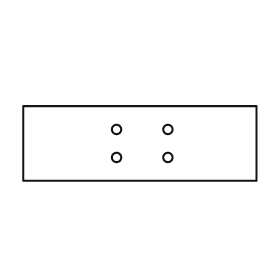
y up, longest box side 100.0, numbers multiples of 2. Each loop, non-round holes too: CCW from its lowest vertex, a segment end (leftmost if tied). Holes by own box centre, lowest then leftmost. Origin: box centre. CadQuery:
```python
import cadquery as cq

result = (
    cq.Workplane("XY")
    .moveTo(-50.0, -16.0)
    .lineTo(50.0, -16.0)
    .lineTo(50.0, 16.0)
    .lineTo(-50.0, 16.0)
    .close()
    .moveTo(-10.0, -6.0)
    .circle(2.0)
    .moveTo(12.0, -6.0)
    .circle(2.0)
    .moveTo(-10.0, 6.0)
    .circle(2.0)
    .moveTo(12.0, 6.0)
    .circle(2.0)
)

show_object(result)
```